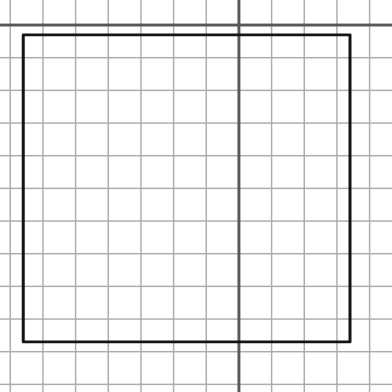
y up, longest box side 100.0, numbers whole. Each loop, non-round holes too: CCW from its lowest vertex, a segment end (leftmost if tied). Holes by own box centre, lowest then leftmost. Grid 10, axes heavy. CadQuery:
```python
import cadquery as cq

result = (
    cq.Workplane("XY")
    .moveTo(-66.0, -97.0)
    .lineTo(34.0, -97.0)
    .lineTo(34.0, -3.0)
    .lineTo(-66.0, -3.0)
    .close()
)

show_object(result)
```